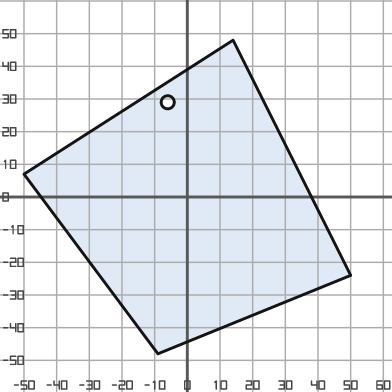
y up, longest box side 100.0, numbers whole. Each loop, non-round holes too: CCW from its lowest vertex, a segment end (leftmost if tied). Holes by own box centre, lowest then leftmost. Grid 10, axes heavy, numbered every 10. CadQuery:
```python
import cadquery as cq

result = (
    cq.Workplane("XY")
    .moveTo(-9.0, -48.0)
    .lineTo(50.0, -24.0)
    .lineTo(14.0, 48.0)
    .lineTo(-50.0, 7.0)
    .close()
    .moveTo(-6.0, 29.0)
    .circle(2.0)
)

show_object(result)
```